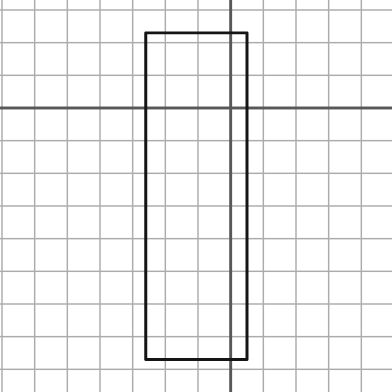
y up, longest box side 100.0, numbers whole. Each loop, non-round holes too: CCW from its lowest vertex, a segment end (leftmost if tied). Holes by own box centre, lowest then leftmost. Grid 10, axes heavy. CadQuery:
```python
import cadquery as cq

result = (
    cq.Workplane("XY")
    .moveTo(-26.0, -77.0)
    .lineTo(5.0, -77.0)
    .lineTo(5.0, 23.0)
    .lineTo(-26.0, 23.0)
    .close()
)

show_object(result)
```